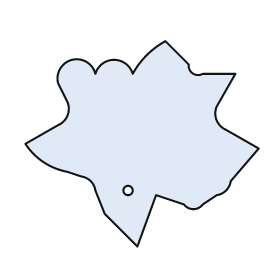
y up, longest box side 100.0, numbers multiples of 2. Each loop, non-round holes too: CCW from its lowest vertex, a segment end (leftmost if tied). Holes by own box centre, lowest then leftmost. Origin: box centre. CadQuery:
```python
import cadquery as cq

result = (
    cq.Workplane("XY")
    .moveTo(-2.0, -44.0)
    .lineTo(6.0, -22.0)
    .lineTo(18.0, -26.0)
    .threePointArc((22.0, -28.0), (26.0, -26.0))
    .lineTo(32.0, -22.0)
    .threePointArc((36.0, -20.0), (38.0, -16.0))
    .lineTo(50.0, -2.0)
    .lineTo(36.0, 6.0)
    .threePointArc((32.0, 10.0), (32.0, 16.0))
    .lineTo(40.0, 30.0)
    .lineTo(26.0, 30.0)
    .threePointArc((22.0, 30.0), (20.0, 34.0))
    .lineTo(10.0, 44.0)
    .threePointArc((2.0, 38.0), (-4.0, 30.0))
    .threePointArc((-12.0, 36.0), (-20.0, 30.0))
    .threePointArc((-30.0, 36.0), (-36.0, 26.0))
    .lineTo(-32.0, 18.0)
    .threePointArc((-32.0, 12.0), (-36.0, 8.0))
    .lineTo(-50.0, 0.0)
    .threePointArc((-42.0, -8.0), (-32.0, -12.0))
    .lineTo(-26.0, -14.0)
    .threePointArc((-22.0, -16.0), (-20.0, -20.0))
    .lineTo(-16.0, -30.0)
    .close()
    .moveTo(-6.0, -20.0)
    .circle(2.0)
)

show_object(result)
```